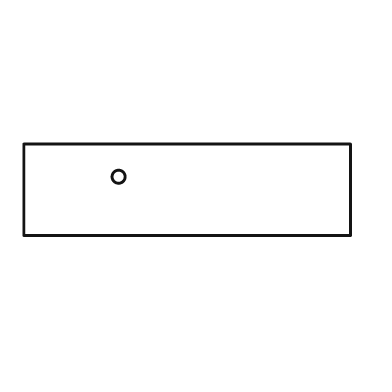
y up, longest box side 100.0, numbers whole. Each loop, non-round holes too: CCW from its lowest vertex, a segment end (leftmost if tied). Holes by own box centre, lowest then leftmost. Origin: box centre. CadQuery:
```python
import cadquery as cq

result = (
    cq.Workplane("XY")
    .moveTo(-50.0, -14.0)
    .lineTo(50.0, -14.0)
    .lineTo(50.0, 14.0)
    .lineTo(-50.0, 14.0)
    .close()
    .moveTo(-21.0, 4.0)
    .circle(2.0)
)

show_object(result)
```